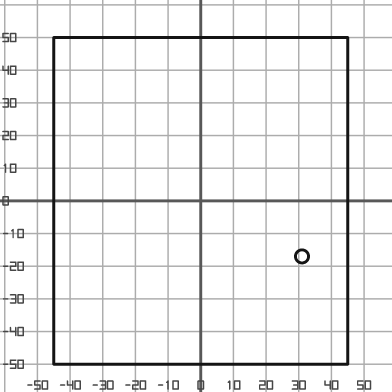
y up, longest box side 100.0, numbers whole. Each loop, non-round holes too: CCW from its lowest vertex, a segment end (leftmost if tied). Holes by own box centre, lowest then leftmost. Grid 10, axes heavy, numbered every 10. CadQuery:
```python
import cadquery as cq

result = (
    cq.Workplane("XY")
    .moveTo(-45.0, -50.0)
    .lineTo(45.0, -50.0)
    .lineTo(45.0, 50.0)
    .lineTo(-45.0, 50.0)
    .close()
    .moveTo(31.0, -17.0)
    .circle(2.0)
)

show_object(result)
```